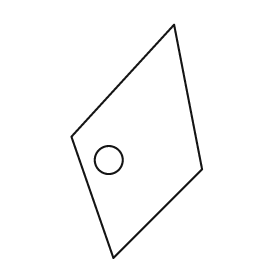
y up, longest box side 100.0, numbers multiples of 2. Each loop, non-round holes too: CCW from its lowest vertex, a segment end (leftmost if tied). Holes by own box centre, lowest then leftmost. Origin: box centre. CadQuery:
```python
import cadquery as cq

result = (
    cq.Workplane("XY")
    .moveTo(-10.0, -50.0)
    .lineTo(28.0, -12.0)
    .lineTo(16.0, 50.0)
    .lineTo(-28.0, 2.0)
    .close()
    .moveTo(-12.0, -8.0)
    .circle(6.0)
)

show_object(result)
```